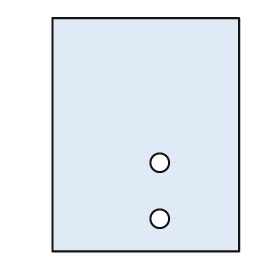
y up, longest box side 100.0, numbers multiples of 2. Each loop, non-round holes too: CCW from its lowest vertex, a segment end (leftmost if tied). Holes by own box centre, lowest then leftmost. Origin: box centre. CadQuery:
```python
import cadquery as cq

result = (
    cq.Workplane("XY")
    .moveTo(-40.0, -50.0)
    .lineTo(40.0, -50.0)
    .lineTo(40.0, 50.0)
    .lineTo(-40.0, 50.0)
    .close()
    .moveTo(6.0, -36.0)
    .circle(4.0)
    .moveTo(6.0, -12.0)
    .circle(4.0)
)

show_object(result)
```